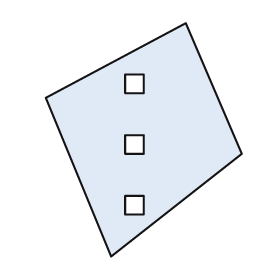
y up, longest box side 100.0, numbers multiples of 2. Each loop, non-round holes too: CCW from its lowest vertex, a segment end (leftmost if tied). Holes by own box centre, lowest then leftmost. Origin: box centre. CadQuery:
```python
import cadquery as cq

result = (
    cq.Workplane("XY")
    .moveTo(-14.0, -50.0)
    .lineTo(42.0, -6.0)
    .lineTo(18.0, 50.0)
    .lineTo(-42.0, 18.0)
    .close()
    .moveTo(-8.0, -32.0)
    .lineTo(0.0, -32.0)
    .lineTo(0.0, -24.0)
    .lineTo(-8.0, -24.0)
    .close()
    .moveTo(-8.0, -6.0)
    .lineTo(0.0, -6.0)
    .lineTo(0.0, 2.0)
    .lineTo(-8.0, 2.0)
    .close()
    .moveTo(-8.0, 20.0)
    .lineTo(0.0, 20.0)
    .lineTo(0.0, 28.0)
    .lineTo(-8.0, 28.0)
    .close()
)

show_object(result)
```